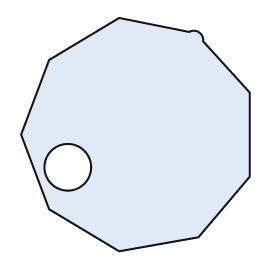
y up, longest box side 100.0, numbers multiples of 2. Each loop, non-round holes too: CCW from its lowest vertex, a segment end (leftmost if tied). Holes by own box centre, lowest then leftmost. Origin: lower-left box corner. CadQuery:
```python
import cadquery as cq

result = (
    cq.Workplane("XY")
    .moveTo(42.0, 0.0)
    .lineTo(76.0, 6.0)
    .lineTo(98.0, 32.0)
    .lineTo(98.0, 68.0)
    .lineTo(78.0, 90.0)
    .threePointArc((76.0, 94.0), (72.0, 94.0))
    .lineTo(42.0, 100.0)
    .lineTo(12.0, 82.0)
    .lineTo(0.0, 50.0)
    .lineTo(12.0, 18.0)
    .close()
    .moveTo(20.0, 36.0)
    .circle(10.0)
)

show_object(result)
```